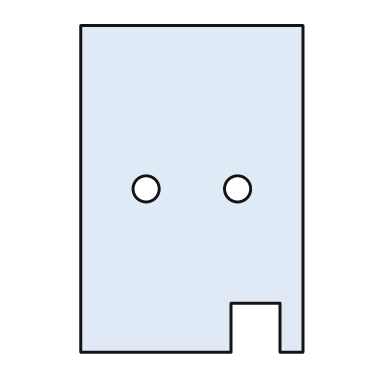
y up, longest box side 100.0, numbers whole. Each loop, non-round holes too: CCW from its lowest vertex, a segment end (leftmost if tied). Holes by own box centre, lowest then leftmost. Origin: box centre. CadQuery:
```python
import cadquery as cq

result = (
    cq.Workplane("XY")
    .moveTo(-34.0, -50.0)
    .lineTo(12.0, -50.0)
    .lineTo(12.0, -35.0)
    .lineTo(27.0, -35.0)
    .lineTo(27.0, -50.0)
    .lineTo(34.0, -50.0)
    .lineTo(34.0, 50.0)
    .lineTo(-34.0, 50.0)
    .close()
    .moveTo(-14.0, 0.0)
    .circle(4.0)
    .moveTo(14.0, 0.0)
    .circle(4.0)
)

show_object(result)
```